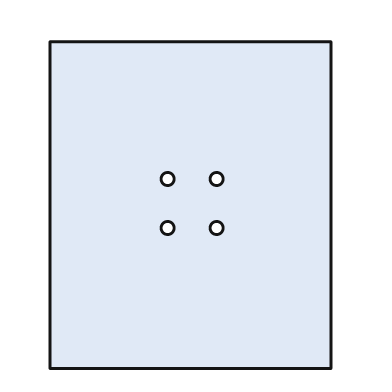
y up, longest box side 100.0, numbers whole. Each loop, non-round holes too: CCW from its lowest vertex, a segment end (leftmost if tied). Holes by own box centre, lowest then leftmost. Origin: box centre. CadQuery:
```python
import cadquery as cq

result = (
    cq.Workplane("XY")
    .moveTo(-43.0, -50.0)
    .lineTo(43.0, -50.0)
    .lineTo(43.0, 50.0)
    .lineTo(-43.0, 50.0)
    .close()
    .moveTo(-7.0, -7.0)
    .circle(2.0)
    .moveTo(8.0, -7.0)
    .circle(2.0)
    .moveTo(-7.0, 8.0)
    .circle(2.0)
    .moveTo(8.0, 8.0)
    .circle(2.0)
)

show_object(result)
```